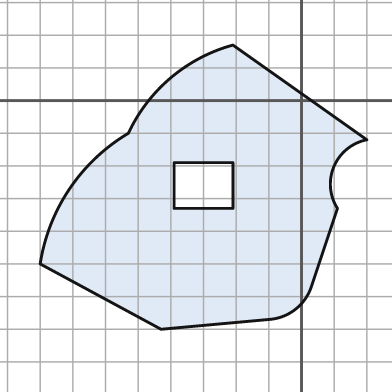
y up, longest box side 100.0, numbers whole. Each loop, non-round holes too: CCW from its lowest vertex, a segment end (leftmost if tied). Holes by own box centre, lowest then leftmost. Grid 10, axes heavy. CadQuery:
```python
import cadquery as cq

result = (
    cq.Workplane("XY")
    .moveTo(-43.0, -70.0)
    .lineTo(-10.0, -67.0)
    .threePointArc((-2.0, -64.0), (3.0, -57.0))
    .lineTo(11.0, -33.0)
    .threePointArc((10.0, -20.0), (20.0, -12.0))
    .lineTo(-21.0, 17.0)
    .threePointArc((-40.0, 7.0), (-53.0, -10.0))
    .threePointArc((-71.0, -27.0), (-80.0, -50.0))
    .close()
    .moveTo(-39.0, -33.0)
    .lineTo(-21.0, -33.0)
    .lineTo(-21.0, -19.0)
    .lineTo(-39.0, -19.0)
    .close()
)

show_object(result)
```